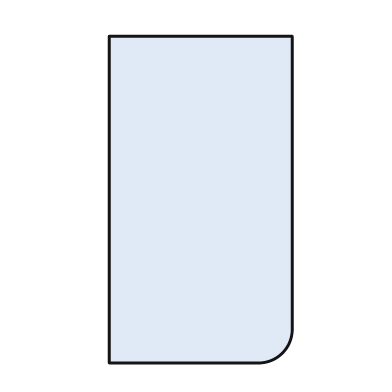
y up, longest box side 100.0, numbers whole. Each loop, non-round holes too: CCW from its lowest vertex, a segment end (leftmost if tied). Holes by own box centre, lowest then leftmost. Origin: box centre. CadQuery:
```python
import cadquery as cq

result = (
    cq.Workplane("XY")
    .moveTo(-28.0, -50.0)
    .lineTo(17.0, -50.0)
    .threePointArc((25.0, -47.0), (28.0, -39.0))
    .lineTo(28.0, 50.0)
    .lineTo(-28.0, 50.0)
    .close()
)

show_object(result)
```